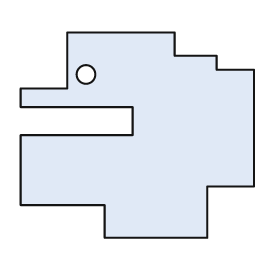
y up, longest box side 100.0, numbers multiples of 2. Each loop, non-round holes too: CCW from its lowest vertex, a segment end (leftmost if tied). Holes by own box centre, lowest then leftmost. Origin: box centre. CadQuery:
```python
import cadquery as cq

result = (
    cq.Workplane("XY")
    .moveTo(-14.0, -44.0)
    .lineTo(30.0, -44.0)
    .lineTo(30.0, -22.0)
    .lineTo(50.0, -22.0)
    .lineTo(50.0, 28.0)
    .lineTo(34.0, 28.0)
    .lineTo(34.0, 34.0)
    .lineTo(16.0, 34.0)
    .lineTo(16.0, 44.0)
    .lineTo(-30.0, 44.0)
    .lineTo(-30.0, 20.0)
    .lineTo(-50.0, 20.0)
    .lineTo(-50.0, 12.0)
    .lineTo(-2.0, 12.0)
    .lineTo(-2.0, 0.0)
    .lineTo(-50.0, 0.0)
    .lineTo(-50.0, -30.0)
    .lineTo(-14.0, -30.0)
    .close()
    .moveTo(-22.0, 26.0)
    .circle(4.0)
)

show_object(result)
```